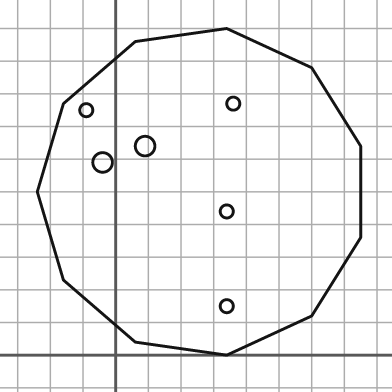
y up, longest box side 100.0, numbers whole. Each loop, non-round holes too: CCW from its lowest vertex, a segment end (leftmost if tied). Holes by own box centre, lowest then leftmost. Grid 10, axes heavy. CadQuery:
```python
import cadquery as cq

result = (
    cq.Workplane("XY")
    .moveTo(34.0, 0.0)
    .lineTo(60.0, 12.0)
    .lineTo(75.0, 36.0)
    .lineTo(75.0, 64.0)
    .lineTo(60.0, 88.0)
    .lineTo(34.0, 100.0)
    .lineTo(6.0, 96.0)
    .lineTo(-16.0, 77.0)
    .lineTo(-24.0, 50.0)
    .lineTo(-16.0, 23.0)
    .lineTo(6.0, 4.0)
    .close()
    .moveTo(34.0, 15.0)
    .circle(2.0)
    .moveTo(34.0, 44.0)
    .circle(2.0)
    .moveTo(-4.0, 59.0)
    .circle(3.0)
    .moveTo(9.0, 64.0)
    .circle(3.0)
    .moveTo(-9.0, 75.0)
    .circle(2.0)
    .moveTo(36.0, 77.0)
    .circle(2.0)
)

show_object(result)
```